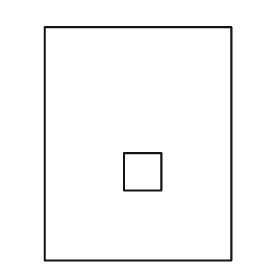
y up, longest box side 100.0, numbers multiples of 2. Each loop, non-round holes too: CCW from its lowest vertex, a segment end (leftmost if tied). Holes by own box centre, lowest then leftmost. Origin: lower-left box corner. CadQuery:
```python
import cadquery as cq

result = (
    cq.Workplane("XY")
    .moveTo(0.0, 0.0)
    .lineTo(80.0, 0.0)
    .lineTo(80.0, 100.0)
    .lineTo(0.0, 100.0)
    .close()
    .moveTo(34.0, 30.0)
    .lineTo(50.0, 30.0)
    .lineTo(50.0, 46.0)
    .lineTo(34.0, 46.0)
    .close()
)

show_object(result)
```